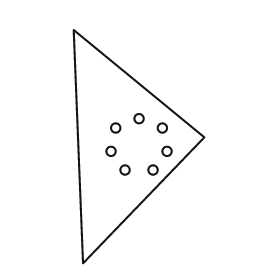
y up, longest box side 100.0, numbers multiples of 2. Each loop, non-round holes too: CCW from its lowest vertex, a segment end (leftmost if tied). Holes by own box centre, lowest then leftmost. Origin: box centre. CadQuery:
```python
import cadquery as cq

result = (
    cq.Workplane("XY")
    .moveTo(-24.0, -50.0)
    .lineTo(28.0, 4.0)
    .lineTo(-28.0, 50.0)
    .close()
    .moveTo(-6.0, -10.0)
    .circle(2.0)
    .moveTo(6.0, -10.0)
    .circle(2.0)
    .moveTo(-12.0, -2.0)
    .circle(2.0)
    .moveTo(12.0, -2.0)
    .circle(2.0)
    .moveTo(-10.0, 8.0)
    .circle(2.0)
    .moveTo(10.0, 8.0)
    .circle(2.0)
    .moveTo(0.0, 12.0)
    .circle(2.0)
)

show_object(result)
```